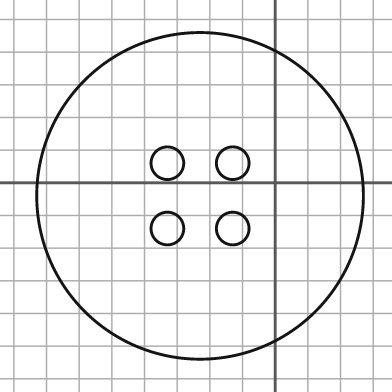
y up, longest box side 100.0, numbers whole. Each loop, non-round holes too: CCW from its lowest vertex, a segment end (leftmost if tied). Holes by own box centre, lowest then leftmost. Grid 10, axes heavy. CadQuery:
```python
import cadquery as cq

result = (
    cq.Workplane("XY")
    .moveTo(-23.0, -4.0)
    .circle(50.0)
    .moveTo(-33.0, -14.0)
    .circle(5.0)
    .moveTo(-13.0, -14.0)
    .circle(5.0)
    .moveTo(-33.0, 6.0)
    .circle(5.0)
    .moveTo(-13.0, 6.0)
    .circle(5.0)
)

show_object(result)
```